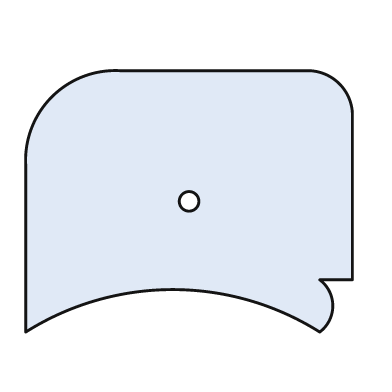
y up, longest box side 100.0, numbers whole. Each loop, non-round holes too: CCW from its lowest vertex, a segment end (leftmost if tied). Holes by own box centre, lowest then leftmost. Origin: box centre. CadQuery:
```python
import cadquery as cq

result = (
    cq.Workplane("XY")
    .moveTo(-50.0, -40.0)
    .threePointArc((-5.0, -27.0), (40.0, -40.0))
    .threePointArc((44.0, -32.0), (40.0, -24.0))
    .lineTo(50.0, -24.0)
    .lineTo(50.0, 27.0)
    .threePointArc((46.0, 36.0), (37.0, 40.0))
    .lineTo(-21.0, 40.0)
    .threePointArc((-42.0, 32.0), (-50.0, 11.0))
    .close()
    .moveTo(0.0, 0.0)
    .circle(3.0)
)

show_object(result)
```